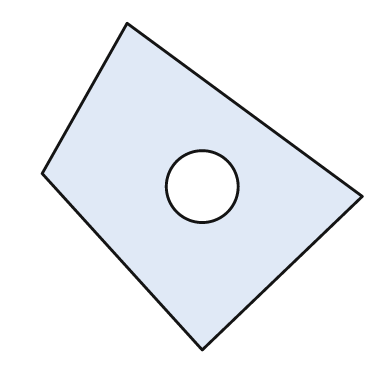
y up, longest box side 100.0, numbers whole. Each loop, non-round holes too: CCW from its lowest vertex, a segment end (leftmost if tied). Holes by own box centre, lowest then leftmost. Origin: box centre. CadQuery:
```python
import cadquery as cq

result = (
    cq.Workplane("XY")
    .moveTo(0.0, -50.0)
    .lineTo(49.0, -3.0)
    .lineTo(-23.0, 50.0)
    .lineTo(-49.0, 4.0)
    .close()
    .moveTo(0.0, 0.0)
    .circle(11.0)
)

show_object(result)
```